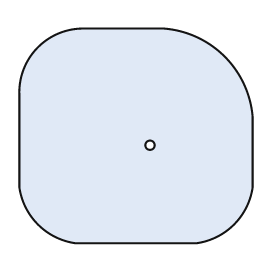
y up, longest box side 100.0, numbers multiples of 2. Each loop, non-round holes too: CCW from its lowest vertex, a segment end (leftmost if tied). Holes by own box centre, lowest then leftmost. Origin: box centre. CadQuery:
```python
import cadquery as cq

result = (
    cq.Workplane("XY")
    .moveTo(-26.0, -46.0)
    .lineTo(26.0, -46.0)
    .threePointArc((42.0, -38.0), (50.0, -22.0))
    .lineTo(50.0, 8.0)
    .threePointArc((38.0, 34.0), (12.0, 46.0))
    .lineTo(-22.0, 46.0)
    .threePointArc((-42.0, 38.0), (-50.0, 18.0))
    .lineTo(-50.0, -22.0)
    .threePointArc((-42.0, -38.0), (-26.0, -46.0))
    .close()
    .moveTo(6.0, -4.0)
    .circle(2.0)
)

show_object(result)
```